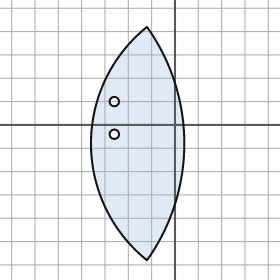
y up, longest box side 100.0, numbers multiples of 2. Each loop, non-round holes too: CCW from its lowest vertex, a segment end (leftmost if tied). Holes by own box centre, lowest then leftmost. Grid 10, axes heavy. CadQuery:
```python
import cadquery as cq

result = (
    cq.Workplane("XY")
    .moveTo(-12.0, -58.0)
    .threePointArc((4.0, -8.0), (-12.0, 42.0))
    .threePointArc((-36.0, -8.0), (-12.0, -58.0))
    .close()
    .moveTo(-26.0, -4.0)
    .circle(2.0)
    .moveTo(-26.0, 10.0)
    .circle(2.0)
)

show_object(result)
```